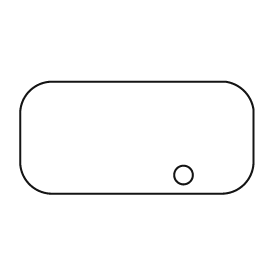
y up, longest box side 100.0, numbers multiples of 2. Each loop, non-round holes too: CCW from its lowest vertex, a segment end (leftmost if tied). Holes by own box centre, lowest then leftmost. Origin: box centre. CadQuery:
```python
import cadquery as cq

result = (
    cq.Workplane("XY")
    .moveTo(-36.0, -24.0)
    .lineTo(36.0, -24.0)
    .threePointArc((46.0, -20.0), (50.0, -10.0))
    .lineTo(50.0, 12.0)
    .threePointArc((46.0, 20.0), (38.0, 24.0))
    .lineTo(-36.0, 24.0)
    .threePointArc((-46.0, 20.0), (-50.0, 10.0))
    .lineTo(-50.0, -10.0)
    .threePointArc((-46.0, -20.0), (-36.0, -24.0))
    .close()
    .moveTo(20.0, -16.0)
    .circle(4.0)
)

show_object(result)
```